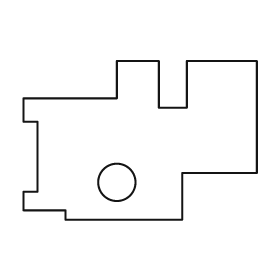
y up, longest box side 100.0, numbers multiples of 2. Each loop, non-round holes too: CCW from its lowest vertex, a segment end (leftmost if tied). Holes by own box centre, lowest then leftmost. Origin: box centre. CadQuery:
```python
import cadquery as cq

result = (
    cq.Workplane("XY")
    .moveTo(-32.0, -34.0)
    .lineTo(18.0, -34.0)
    .lineTo(18.0, -14.0)
    .lineTo(50.0, -14.0)
    .lineTo(50.0, 34.0)
    .lineTo(20.0, 34.0)
    .lineTo(20.0, 14.0)
    .lineTo(8.0, 14.0)
    .lineTo(8.0, 34.0)
    .lineTo(-10.0, 34.0)
    .lineTo(-10.0, 18.0)
    .lineTo(-50.0, 18.0)
    .lineTo(-50.0, 8.0)
    .lineTo(-44.0, 8.0)
    .lineTo(-44.0, -22.0)
    .lineTo(-50.0, -22.0)
    .lineTo(-50.0, -30.0)
    .lineTo(-32.0, -30.0)
    .close()
    .moveTo(-10.0, -18.0)
    .circle(8.0)
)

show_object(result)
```